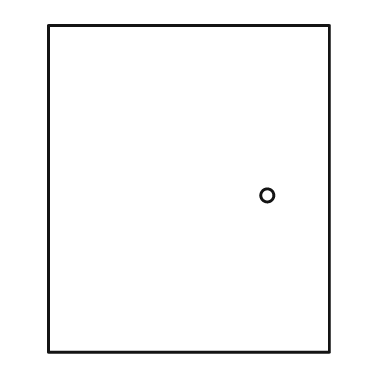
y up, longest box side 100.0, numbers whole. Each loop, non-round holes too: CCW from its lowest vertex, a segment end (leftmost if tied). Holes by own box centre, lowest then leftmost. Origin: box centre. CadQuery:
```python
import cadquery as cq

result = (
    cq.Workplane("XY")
    .moveTo(-43.0, -50.0)
    .lineTo(43.0, -50.0)
    .lineTo(43.0, 50.0)
    .lineTo(-43.0, 50.0)
    .close()
    .moveTo(24.0, -2.0)
    .circle(2.0)
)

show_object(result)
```